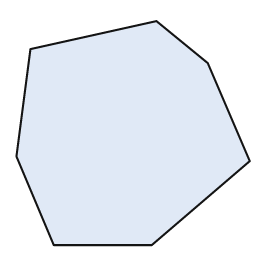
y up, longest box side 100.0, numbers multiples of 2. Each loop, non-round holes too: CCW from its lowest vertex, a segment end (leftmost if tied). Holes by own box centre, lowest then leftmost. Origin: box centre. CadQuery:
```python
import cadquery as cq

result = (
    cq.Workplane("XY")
    .moveTo(-34.0, -48.0)
    .lineTo(8.0, -48.0)
    .lineTo(50.0, -12.0)
    .lineTo(32.0, 30.0)
    .lineTo(10.0, 48.0)
    .lineTo(-44.0, 36.0)
    .lineTo(-50.0, -10.0)
    .close()
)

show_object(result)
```